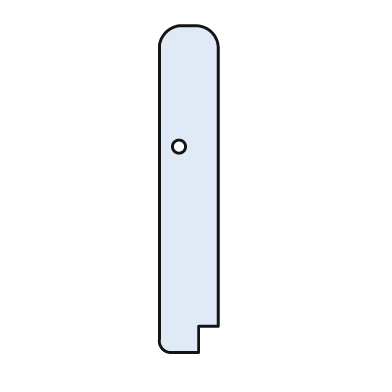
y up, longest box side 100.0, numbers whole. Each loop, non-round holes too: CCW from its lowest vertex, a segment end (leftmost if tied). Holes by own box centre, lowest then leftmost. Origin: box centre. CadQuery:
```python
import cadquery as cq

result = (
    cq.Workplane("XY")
    .moveTo(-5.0, -50.0)
    .lineTo(3.0, -50.0)
    .lineTo(3.0, -42.0)
    .lineTo(9.0, -42.0)
    .lineTo(9.0, 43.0)
    .threePointArc((7.0, 48.0), (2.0, 50.0))
    .lineTo(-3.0, 50.0)
    .threePointArc((-7.0, 48.0), (-9.0, 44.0))
    .lineTo(-9.0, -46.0)
    .threePointArc((-8.0, -49.0), (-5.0, -50.0))
    .close()
    .moveTo(-3.0, 13.0)
    .circle(2.0)
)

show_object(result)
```